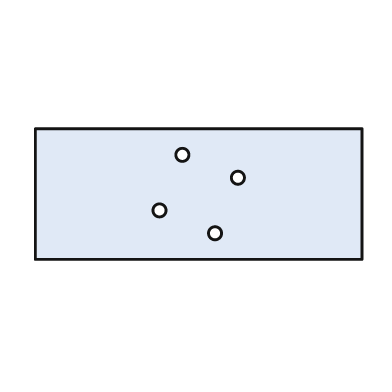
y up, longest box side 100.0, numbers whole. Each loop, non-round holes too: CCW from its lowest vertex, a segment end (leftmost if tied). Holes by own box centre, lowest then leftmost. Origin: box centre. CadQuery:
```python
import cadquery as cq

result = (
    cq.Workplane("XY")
    .moveTo(-50.0, -20.0)
    .lineTo(50.0, -20.0)
    .lineTo(50.0, 20.0)
    .lineTo(-50.0, 20.0)
    .close()
    .moveTo(5.0, -12.0)
    .circle(2.0)
    .moveTo(-12.0, -5.0)
    .circle(2.0)
    .moveTo(12.0, 5.0)
    .circle(2.0)
    .moveTo(-5.0, 12.0)
    .circle(2.0)
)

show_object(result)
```